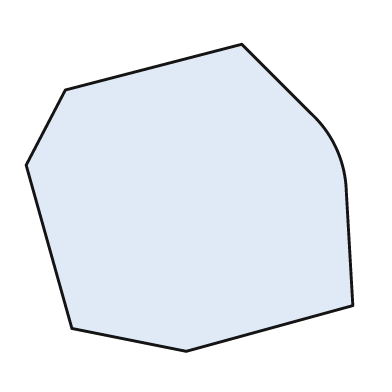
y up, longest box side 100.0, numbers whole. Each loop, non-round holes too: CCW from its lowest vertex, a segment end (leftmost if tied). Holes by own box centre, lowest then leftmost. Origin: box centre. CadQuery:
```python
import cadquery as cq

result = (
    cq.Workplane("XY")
    .moveTo(-1.0, -47.0)
    .lineTo(50.0, -33.0)
    .lineTo(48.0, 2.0)
    .threePointArc((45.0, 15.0), (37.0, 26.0))
    .lineTo(16.0, 47.0)
    .lineTo(-38.0, 33.0)
    .lineTo(-50.0, 10.0)
    .lineTo(-36.0, -40.0)
    .close()
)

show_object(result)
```